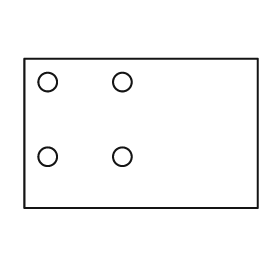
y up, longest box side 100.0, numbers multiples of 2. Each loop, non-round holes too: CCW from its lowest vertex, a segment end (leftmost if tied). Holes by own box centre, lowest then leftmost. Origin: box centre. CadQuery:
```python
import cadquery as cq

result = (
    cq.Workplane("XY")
    .moveTo(-50.0, -32.0)
    .lineTo(50.0, -32.0)
    .lineTo(50.0, 32.0)
    .lineTo(-50.0, 32.0)
    .close()
    .moveTo(-40.0, -10.0)
    .circle(4.0)
    .moveTo(-8.0, -10.0)
    .circle(4.0)
    .moveTo(-40.0, 22.0)
    .circle(4.0)
    .moveTo(-8.0, 22.0)
    .circle(4.0)
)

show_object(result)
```